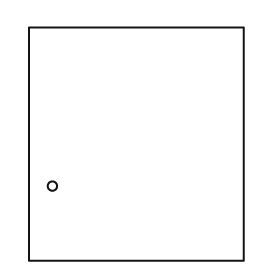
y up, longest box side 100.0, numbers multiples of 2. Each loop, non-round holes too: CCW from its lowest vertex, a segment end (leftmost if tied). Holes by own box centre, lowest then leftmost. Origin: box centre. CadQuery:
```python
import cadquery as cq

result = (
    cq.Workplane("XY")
    .moveTo(-46.0, -50.0)
    .lineTo(46.0, -50.0)
    .lineTo(46.0, 50.0)
    .lineTo(-46.0, 50.0)
    .close()
    .moveTo(-36.0, -18.0)
    .circle(2.0)
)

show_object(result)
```